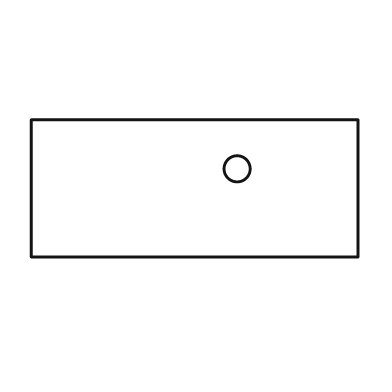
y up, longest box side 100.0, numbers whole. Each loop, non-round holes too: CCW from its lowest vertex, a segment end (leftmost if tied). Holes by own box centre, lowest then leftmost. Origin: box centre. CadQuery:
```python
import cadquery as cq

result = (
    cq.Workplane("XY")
    .moveTo(-50.0, -21.0)
    .lineTo(50.0, -21.0)
    .lineTo(50.0, 21.0)
    .lineTo(-50.0, 21.0)
    .close()
    .moveTo(13.0, 6.0)
    .circle(4.0)
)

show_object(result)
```